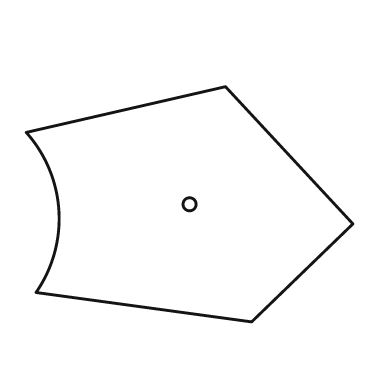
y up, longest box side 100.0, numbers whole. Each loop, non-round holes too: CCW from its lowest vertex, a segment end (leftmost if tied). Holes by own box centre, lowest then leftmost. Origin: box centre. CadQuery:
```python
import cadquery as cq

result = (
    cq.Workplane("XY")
    .moveTo(19.0, -36.0)
    .lineTo(50.0, -6.0)
    .lineTo(11.0, 36.0)
    .lineTo(-50.0, 22.0)
    .threePointArc((-40.0, -2.0), (-47.0, -27.0))
    .close()
    .moveTo(0.0, 0.0)
    .circle(2.0)
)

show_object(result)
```